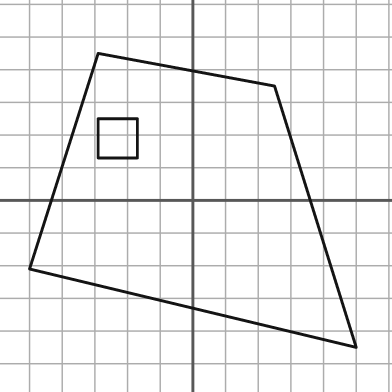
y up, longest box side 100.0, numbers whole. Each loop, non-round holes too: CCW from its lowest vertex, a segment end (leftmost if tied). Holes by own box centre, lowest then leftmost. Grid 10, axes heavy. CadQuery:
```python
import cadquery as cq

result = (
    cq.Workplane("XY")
    .moveTo(50.0, -45.0)
    .lineTo(25.0, 35.0)
    .lineTo(-29.0, 45.0)
    .lineTo(-50.0, -21.0)
    .close()
    .moveTo(-29.0, 13.0)
    .lineTo(-17.0, 13.0)
    .lineTo(-17.0, 25.0)
    .lineTo(-29.0, 25.0)
    .close()
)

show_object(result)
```